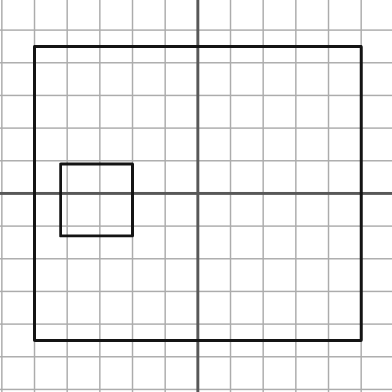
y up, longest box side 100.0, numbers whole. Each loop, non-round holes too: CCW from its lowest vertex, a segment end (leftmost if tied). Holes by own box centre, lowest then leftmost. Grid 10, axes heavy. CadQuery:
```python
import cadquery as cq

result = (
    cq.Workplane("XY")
    .moveTo(-50.0, -45.0)
    .lineTo(50.0, -45.0)
    .lineTo(50.0, 45.0)
    .lineTo(-50.0, 45.0)
    .close()
    .moveTo(-42.0, -13.0)
    .lineTo(-20.0, -13.0)
    .lineTo(-20.0, 9.0)
    .lineTo(-42.0, 9.0)
    .close()
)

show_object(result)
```